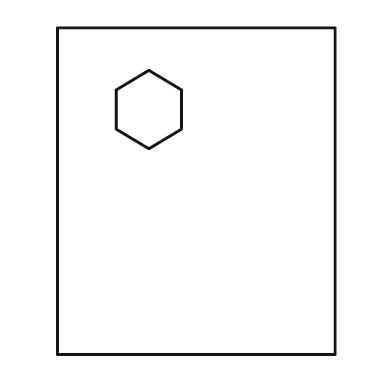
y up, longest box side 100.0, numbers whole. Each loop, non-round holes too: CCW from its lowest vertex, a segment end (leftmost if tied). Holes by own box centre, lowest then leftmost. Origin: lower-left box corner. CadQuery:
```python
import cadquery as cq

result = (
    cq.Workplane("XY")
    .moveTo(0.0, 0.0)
    .lineTo(85.0, 0.0)
    .lineTo(85.0, 100.0)
    .lineTo(0.0, 100.0)
    .close()
    .moveTo(28.0, 63.0)
    .lineTo(38.0, 69.0)
    .lineTo(38.0, 81.0)
    .lineTo(28.0, 87.0)
    .lineTo(18.0, 81.0)
    .lineTo(18.0, 69.0)
    .close()
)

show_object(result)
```